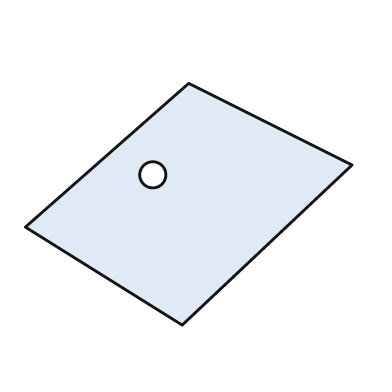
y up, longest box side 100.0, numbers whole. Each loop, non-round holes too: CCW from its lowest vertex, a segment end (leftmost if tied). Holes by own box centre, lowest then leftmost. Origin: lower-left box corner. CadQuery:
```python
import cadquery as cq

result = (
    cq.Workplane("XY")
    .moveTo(48.0, 0.0)
    .lineTo(100.0, 49.0)
    .lineTo(50.0, 74.0)
    .lineTo(0.0, 30.0)
    .close()
    .moveTo(39.0, 46.0)
    .circle(4.0)
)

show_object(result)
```